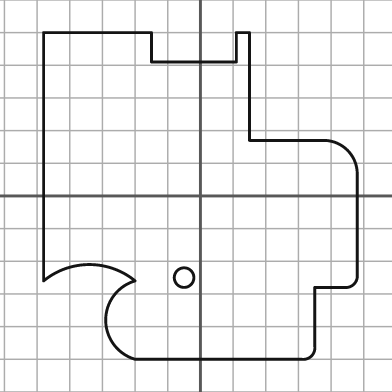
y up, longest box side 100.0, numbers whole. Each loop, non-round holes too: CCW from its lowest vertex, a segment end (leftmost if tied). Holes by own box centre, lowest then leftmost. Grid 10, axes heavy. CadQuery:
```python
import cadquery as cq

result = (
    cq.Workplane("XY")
    .moveTo(-20.0, -50.0)
    .lineTo(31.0, -50.0)
    .threePointArc((34.0, -49.0), (35.0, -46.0))
    .lineTo(35.0, -28.0)
    .lineTo(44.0, -28.0)
    .threePointArc((47.0, -27.0), (48.0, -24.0))
    .lineTo(48.0, 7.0)
    .threePointArc((45.0, 14.0), (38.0, 17.0))
    .lineTo(15.0, 17.0)
    .lineTo(15.0, 50.0)
    .lineTo(11.0, 50.0)
    .lineTo(11.0, 41.0)
    .lineTo(-15.0, 41.0)
    .lineTo(-15.0, 50.0)
    .lineTo(-48.0, 50.0)
    .lineTo(-48.0, -26.0)
    .threePointArc((-34.0, -21.0), (-20.0, -26.0))
    .threePointArc((-29.0, -38.0), (-20.0, -50.0))
    .close()
    .moveTo(-5.0, -25.0)
    .circle(3.0)
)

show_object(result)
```